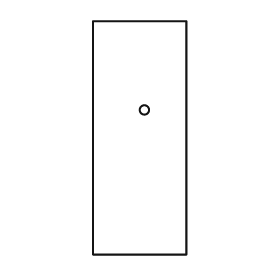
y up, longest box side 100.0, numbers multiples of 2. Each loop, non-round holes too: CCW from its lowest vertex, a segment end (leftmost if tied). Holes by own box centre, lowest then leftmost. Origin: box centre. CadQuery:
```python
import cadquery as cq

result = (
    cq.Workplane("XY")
    .moveTo(-20.0, -50.0)
    .lineTo(20.0, -50.0)
    .lineTo(20.0, 50.0)
    .lineTo(-20.0, 50.0)
    .close()
    .moveTo(2.0, 12.0)
    .circle(2.0)
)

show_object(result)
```